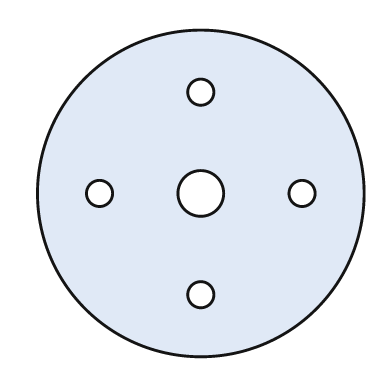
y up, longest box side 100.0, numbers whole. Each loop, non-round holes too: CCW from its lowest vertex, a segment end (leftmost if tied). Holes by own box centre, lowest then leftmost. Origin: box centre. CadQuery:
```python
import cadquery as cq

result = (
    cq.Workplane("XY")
    .moveTo(0.0, 0.0)
    .circle(50.0)
    .moveTo(0.0, -31.0)
    .circle(4.0)
    .moveTo(-31.0, 0.0)
    .circle(4.0)
    .moveTo(0.0, 0.0)
    .circle(7.0)
    .moveTo(31.0, 0.0)
    .circle(4.0)
    .moveTo(0.0, 31.0)
    .circle(4.0)
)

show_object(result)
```